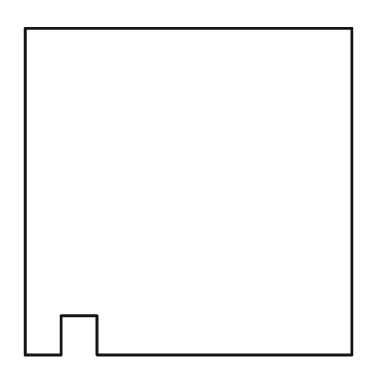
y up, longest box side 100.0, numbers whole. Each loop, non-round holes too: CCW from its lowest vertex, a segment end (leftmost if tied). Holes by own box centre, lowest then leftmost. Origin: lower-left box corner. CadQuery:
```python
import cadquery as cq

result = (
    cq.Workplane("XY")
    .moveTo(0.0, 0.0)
    .lineTo(11.0, 0.0)
    .lineTo(11.0, 12.0)
    .lineTo(22.0, 12.0)
    .lineTo(22.0, 0.0)
    .lineTo(100.0, 0.0)
    .lineTo(100.0, 100.0)
    .lineTo(0.0, 100.0)
    .close()
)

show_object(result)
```